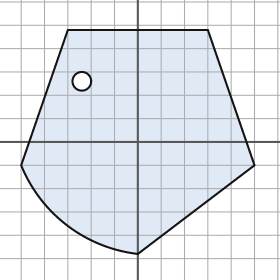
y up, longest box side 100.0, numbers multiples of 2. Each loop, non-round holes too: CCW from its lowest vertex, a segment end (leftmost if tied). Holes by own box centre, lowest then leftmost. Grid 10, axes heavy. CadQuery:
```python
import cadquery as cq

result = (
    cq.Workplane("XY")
    .moveTo(0.0, -48.0)
    .lineTo(50.0, -10.0)
    .lineTo(30.0, 48.0)
    .lineTo(-30.0, 48.0)
    .lineTo(-50.0, -10.0)
    .threePointArc((-30.0, -36.0), (0.0, -48.0))
    .close()
    .moveTo(-24.0, 26.0)
    .circle(4.0)
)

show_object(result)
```